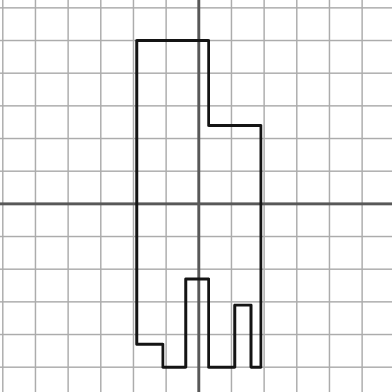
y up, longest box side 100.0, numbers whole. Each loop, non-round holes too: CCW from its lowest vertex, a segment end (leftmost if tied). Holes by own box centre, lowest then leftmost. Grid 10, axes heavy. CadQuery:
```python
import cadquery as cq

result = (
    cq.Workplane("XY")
    .moveTo(-11.0, -50.0)
    .lineTo(-4.0, -50.0)
    .lineTo(-4.0, -23.0)
    .lineTo(3.0, -23.0)
    .lineTo(3.0, -50.0)
    .lineTo(11.0, -50.0)
    .lineTo(11.0, -31.0)
    .lineTo(16.0, -31.0)
    .lineTo(16.0, -50.0)
    .lineTo(19.0, -50.0)
    .lineTo(19.0, 24.0)
    .lineTo(3.0, 24.0)
    .lineTo(3.0, 50.0)
    .lineTo(-19.0, 50.0)
    .lineTo(-19.0, -43.0)
    .lineTo(-11.0, -43.0)
    .close()
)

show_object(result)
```